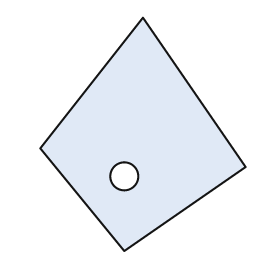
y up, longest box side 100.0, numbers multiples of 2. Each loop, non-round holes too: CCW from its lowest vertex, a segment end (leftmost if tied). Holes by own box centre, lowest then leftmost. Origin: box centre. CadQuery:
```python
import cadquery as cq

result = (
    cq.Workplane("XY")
    .moveTo(-8.0, -50.0)
    .lineTo(44.0, -14.0)
    .lineTo(0.0, 50.0)
    .lineTo(-44.0, -6.0)
    .close()
    .moveTo(-8.0, -18.0)
    .circle(6.0)
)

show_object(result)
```